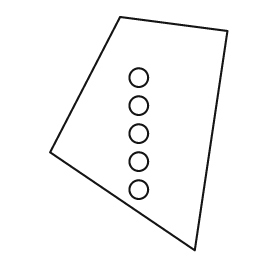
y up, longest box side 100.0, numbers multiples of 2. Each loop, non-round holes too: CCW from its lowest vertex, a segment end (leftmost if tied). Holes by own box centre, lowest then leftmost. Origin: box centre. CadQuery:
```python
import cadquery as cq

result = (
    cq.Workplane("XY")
    .moveTo(24.0, -50.0)
    .lineTo(38.0, 44.0)
    .lineTo(-8.0, 50.0)
    .lineTo(-38.0, -8.0)
    .close()
    .moveTo(0.0, -24.0)
    .circle(4.0)
    .moveTo(0.0, -12.0)
    .circle(4.0)
    .moveTo(0.0, 0.0)
    .circle(4.0)
    .moveTo(0.0, 12.0)
    .circle(4.0)
    .moveTo(0.0, 24.0)
    .circle(4.0)
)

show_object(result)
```